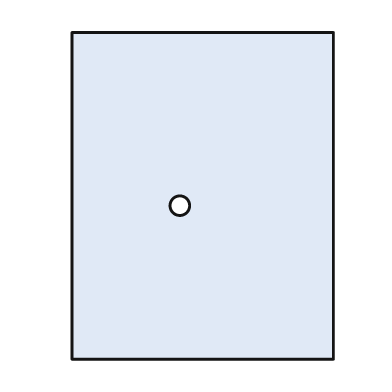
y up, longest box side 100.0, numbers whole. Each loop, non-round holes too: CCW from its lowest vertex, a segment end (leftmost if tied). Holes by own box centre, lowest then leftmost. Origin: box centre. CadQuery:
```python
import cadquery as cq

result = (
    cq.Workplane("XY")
    .moveTo(-40.0, -50.0)
    .lineTo(40.0, -50.0)
    .lineTo(40.0, 50.0)
    .lineTo(-40.0, 50.0)
    .close()
    .moveTo(-7.0, -3.0)
    .circle(3.0)
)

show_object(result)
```